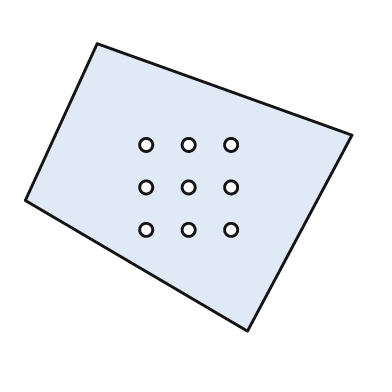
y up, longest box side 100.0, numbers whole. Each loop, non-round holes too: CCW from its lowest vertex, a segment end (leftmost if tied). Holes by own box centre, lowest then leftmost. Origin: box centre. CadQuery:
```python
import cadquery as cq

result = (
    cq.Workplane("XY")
    .moveTo(18.0, -44.0)
    .lineTo(50.0, 16.0)
    .lineTo(-28.0, 44.0)
    .lineTo(-50.0, -4.0)
    .close()
    .moveTo(-13.0, -13.0)
    .circle(2.0)
    .moveTo(0.0, -13.0)
    .circle(2.0)
    .moveTo(13.0, -13.0)
    .circle(2.0)
    .moveTo(-13.0, 0.0)
    .circle(2.0)
    .moveTo(0.0, 0.0)
    .circle(2.0)
    .moveTo(13.0, 0.0)
    .circle(2.0)
    .moveTo(-13.0, 13.0)
    .circle(2.0)
    .moveTo(0.0, 13.0)
    .circle(2.0)
    .moveTo(13.0, 13.0)
    .circle(2.0)
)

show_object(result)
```